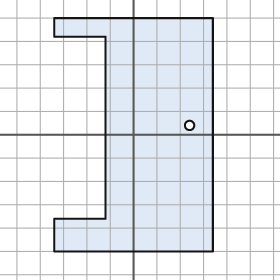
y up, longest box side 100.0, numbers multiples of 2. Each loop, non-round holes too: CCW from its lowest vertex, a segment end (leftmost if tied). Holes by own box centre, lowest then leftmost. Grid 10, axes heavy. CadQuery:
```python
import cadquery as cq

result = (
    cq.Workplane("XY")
    .moveTo(-34.0, -50.0)
    .lineTo(34.0, -50.0)
    .lineTo(34.0, 50.0)
    .lineTo(-34.0, 50.0)
    .lineTo(-34.0, 42.0)
    .lineTo(-12.0, 42.0)
    .lineTo(-12.0, -36.0)
    .lineTo(-34.0, -36.0)
    .close()
    .moveTo(24.0, 4.0)
    .circle(2.0)
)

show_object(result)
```